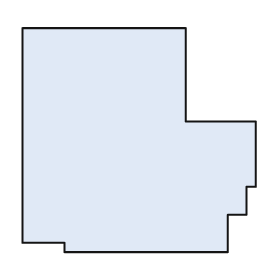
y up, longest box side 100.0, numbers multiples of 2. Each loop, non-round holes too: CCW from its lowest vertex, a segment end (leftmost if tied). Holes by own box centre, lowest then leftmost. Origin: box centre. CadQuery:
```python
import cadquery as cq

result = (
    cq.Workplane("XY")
    .moveTo(-32.0, -48.0)
    .lineTo(38.0, -48.0)
    .lineTo(38.0, -32.0)
    .lineTo(46.0, -32.0)
    .lineTo(46.0, -20.0)
    .lineTo(50.0, -20.0)
    .lineTo(50.0, 8.0)
    .lineTo(20.0, 8.0)
    .lineTo(20.0, 48.0)
    .lineTo(-50.0, 48.0)
    .lineTo(-50.0, -44.0)
    .lineTo(-32.0, -44.0)
    .close()
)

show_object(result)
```